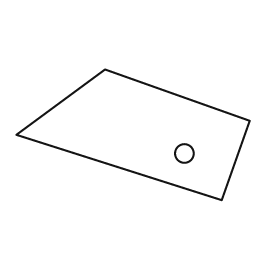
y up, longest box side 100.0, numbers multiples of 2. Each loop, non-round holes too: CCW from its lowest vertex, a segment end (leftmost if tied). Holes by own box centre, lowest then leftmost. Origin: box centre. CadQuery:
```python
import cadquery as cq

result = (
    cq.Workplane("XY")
    .moveTo(38.0, -28.0)
    .lineTo(50.0, 6.0)
    .lineTo(-12.0, 28.0)
    .lineTo(-50.0, 0.0)
    .close()
    .moveTo(22.0, -8.0)
    .circle(4.0)
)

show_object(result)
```